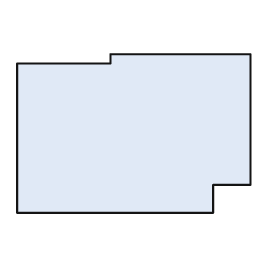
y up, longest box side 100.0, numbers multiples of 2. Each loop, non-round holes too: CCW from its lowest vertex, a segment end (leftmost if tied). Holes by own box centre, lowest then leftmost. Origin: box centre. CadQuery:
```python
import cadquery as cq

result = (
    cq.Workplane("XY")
    .moveTo(-50.0, -34.0)
    .lineTo(34.0, -34.0)
    .lineTo(34.0, -22.0)
    .lineTo(50.0, -22.0)
    .lineTo(50.0, 34.0)
    .lineTo(-10.0, 34.0)
    .lineTo(-10.0, 30.0)
    .lineTo(-50.0, 30.0)
    .close()
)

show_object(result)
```